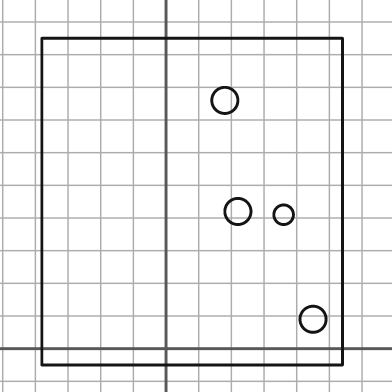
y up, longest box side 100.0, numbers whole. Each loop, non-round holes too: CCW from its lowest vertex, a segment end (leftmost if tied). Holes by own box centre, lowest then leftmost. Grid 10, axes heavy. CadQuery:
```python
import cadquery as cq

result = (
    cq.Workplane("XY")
    .moveTo(-38.0, -5.0)
    .lineTo(54.0, -5.0)
    .lineTo(54.0, 95.0)
    .lineTo(-38.0, 95.0)
    .close()
    .moveTo(45.0, 9.0)
    .circle(4.0)
    .moveTo(36.0, 41.0)
    .circle(3.0)
    .moveTo(22.0, 42.0)
    .circle(4.0)
    .moveTo(18.0, 76.0)
    .circle(4.0)
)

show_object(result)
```